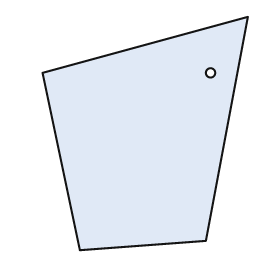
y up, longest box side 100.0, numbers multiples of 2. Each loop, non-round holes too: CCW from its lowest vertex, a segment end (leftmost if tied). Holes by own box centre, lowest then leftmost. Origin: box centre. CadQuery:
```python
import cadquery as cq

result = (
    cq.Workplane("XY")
    .moveTo(-28.0, -50.0)
    .lineTo(26.0, -46.0)
    .lineTo(44.0, 50.0)
    .lineTo(-44.0, 26.0)
    .close()
    .moveTo(28.0, 26.0)
    .circle(2.0)
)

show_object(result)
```